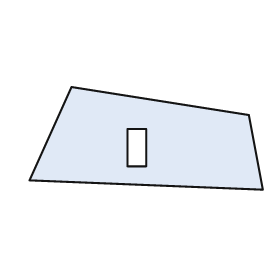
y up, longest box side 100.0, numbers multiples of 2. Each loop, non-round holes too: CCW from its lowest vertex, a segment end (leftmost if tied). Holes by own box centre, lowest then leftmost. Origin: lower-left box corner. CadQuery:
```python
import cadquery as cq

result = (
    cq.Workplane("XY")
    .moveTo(100.0, 0.0)
    .lineTo(94.0, 32.0)
    .lineTo(18.0, 44.0)
    .lineTo(0.0, 4.0)
    .close()
    .moveTo(42.0, 10.0)
    .lineTo(50.0, 10.0)
    .lineTo(50.0, 26.0)
    .lineTo(42.0, 26.0)
    .close()
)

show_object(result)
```